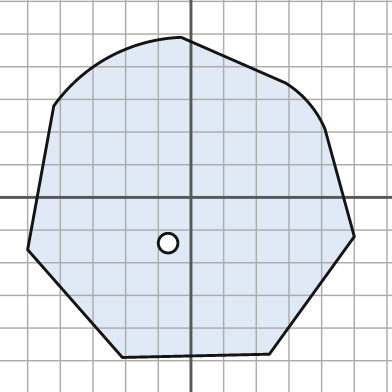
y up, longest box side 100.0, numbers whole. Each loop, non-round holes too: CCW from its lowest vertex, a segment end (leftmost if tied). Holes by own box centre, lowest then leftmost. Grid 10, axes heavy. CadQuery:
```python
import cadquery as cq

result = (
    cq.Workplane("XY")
    .moveTo(-21.0, -49.0)
    .lineTo(24.0, -48.0)
    .lineTo(50.0, -12.0)
    .lineTo(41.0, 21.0)
    .threePointArc((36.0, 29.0), (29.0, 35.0))
    .lineTo(-3.0, 49.0)
    .threePointArc((-25.0, 43.0), (-42.0, 28.0))
    .lineTo(-50.0, -16.0)
    .close()
    .moveTo(-7.0, -14.0)
    .circle(3.0)
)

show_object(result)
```